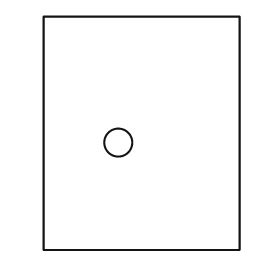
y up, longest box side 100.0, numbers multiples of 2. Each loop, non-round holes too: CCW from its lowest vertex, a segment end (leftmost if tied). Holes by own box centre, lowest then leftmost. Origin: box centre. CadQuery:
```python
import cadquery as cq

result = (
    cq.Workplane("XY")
    .moveTo(-42.0, -50.0)
    .lineTo(42.0, -50.0)
    .lineTo(42.0, 50.0)
    .lineTo(-42.0, 50.0)
    .close()
    .moveTo(-10.0, -4.0)
    .circle(6.0)
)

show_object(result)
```